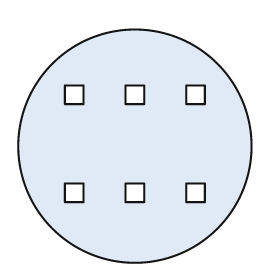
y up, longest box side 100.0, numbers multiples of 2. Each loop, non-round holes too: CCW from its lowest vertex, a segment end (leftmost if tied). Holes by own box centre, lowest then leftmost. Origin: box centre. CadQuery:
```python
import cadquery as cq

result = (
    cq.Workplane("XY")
    .moveTo(0.0, 0.0)
    .circle(50.0)
    .moveTo(-30.0, -24.0)
    .lineTo(-22.0, -24.0)
    .lineTo(-22.0, -16.0)
    .lineTo(-30.0, -16.0)
    .close()
    .moveTo(-4.0, -24.0)
    .lineTo(4.0, -24.0)
    .lineTo(4.0, -16.0)
    .lineTo(-4.0, -16.0)
    .close()
    .moveTo(22.0, -24.0)
    .lineTo(30.0, -24.0)
    .lineTo(30.0, -16.0)
    .lineTo(22.0, -16.0)
    .close()
    .moveTo(-30.0, 18.0)
    .lineTo(-22.0, 18.0)
    .lineTo(-22.0, 26.0)
    .lineTo(-30.0, 26.0)
    .close()
    .moveTo(-4.0, 18.0)
    .lineTo(4.0, 18.0)
    .lineTo(4.0, 26.0)
    .lineTo(-4.0, 26.0)
    .close()
    .moveTo(22.0, 18.0)
    .lineTo(30.0, 18.0)
    .lineTo(30.0, 26.0)
    .lineTo(22.0, 26.0)
    .close()
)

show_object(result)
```